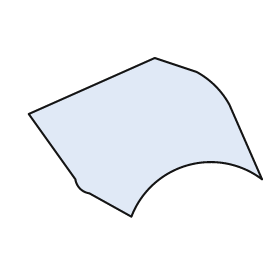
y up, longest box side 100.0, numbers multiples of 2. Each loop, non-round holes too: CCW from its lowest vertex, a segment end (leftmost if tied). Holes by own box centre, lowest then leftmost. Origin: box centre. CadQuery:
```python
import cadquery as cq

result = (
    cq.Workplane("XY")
    .moveTo(-6.0, -34.0)
    .threePointArc((18.0, -12.0), (50.0, -18.0))
    .lineTo(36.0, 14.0)
    .threePointArc((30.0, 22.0), (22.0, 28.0))
    .lineTo(4.0, 34.0)
    .lineTo(-50.0, 10.0)
    .lineTo(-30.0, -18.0)
    .threePointArc((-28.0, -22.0), (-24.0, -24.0))
    .close()
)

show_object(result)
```